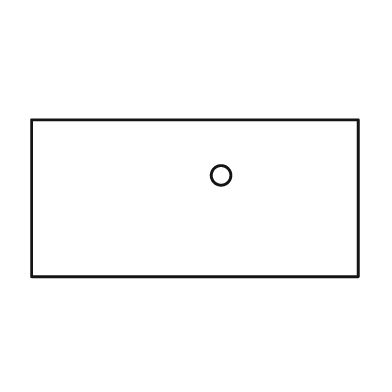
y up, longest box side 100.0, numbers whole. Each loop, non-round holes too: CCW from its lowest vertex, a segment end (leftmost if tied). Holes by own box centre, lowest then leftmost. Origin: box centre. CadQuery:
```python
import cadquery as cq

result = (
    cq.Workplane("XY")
    .moveTo(-50.0, -24.0)
    .lineTo(50.0, -24.0)
    .lineTo(50.0, 24.0)
    .lineTo(-50.0, 24.0)
    .close()
    .moveTo(8.0, 7.0)
    .circle(3.0)
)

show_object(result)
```